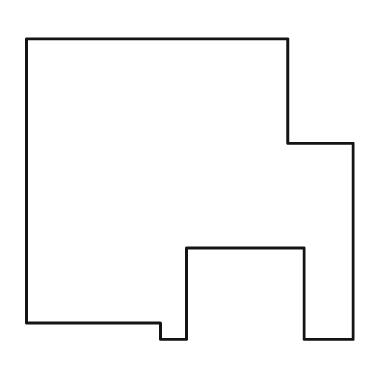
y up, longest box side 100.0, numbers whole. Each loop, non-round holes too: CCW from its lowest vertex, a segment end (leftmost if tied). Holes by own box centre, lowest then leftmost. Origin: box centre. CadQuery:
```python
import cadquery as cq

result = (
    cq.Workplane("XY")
    .moveTo(-9.0, -46.0)
    .lineTo(-1.0, -46.0)
    .lineTo(-1.0, -18.0)
    .lineTo(35.0, -18.0)
    .lineTo(35.0, -46.0)
    .lineTo(50.0, -46.0)
    .lineTo(50.0, 14.0)
    .lineTo(30.0, 14.0)
    .lineTo(30.0, 46.0)
    .lineTo(-50.0, 46.0)
    .lineTo(-50.0, -41.0)
    .lineTo(-9.0, -41.0)
    .close()
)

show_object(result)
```